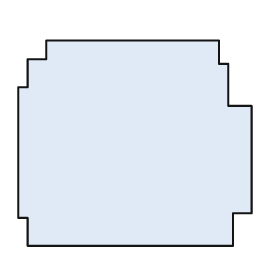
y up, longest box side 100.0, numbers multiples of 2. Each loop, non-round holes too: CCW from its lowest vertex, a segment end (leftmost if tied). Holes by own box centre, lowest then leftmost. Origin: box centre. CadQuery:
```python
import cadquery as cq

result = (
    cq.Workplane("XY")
    .moveTo(-46.0, -44.0)
    .lineTo(42.0, -44.0)
    .lineTo(42.0, -30.0)
    .lineTo(50.0, -30.0)
    .lineTo(50.0, 16.0)
    .lineTo(40.0, 16.0)
    .lineTo(40.0, 34.0)
    .lineTo(36.0, 34.0)
    .lineTo(36.0, 44.0)
    .lineTo(-38.0, 44.0)
    .lineTo(-38.0, 36.0)
    .lineTo(-46.0, 36.0)
    .lineTo(-46.0, 24.0)
    .lineTo(-50.0, 24.0)
    .lineTo(-50.0, -32.0)
    .lineTo(-46.0, -32.0)
    .close()
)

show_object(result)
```